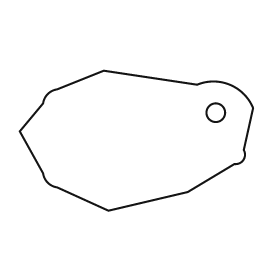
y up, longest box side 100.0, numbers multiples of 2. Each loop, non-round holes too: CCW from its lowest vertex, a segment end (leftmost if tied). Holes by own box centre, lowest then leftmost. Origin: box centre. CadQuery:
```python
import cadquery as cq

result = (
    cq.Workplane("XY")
    .moveTo(-12.0, -30.0)
    .lineTo(22.0, -22.0)
    .lineTo(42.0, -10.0)
    .threePointArc((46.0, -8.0), (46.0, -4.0))
    .lineTo(50.0, 14.0)
    .threePointArc((40.0, 24.0), (26.0, 24.0))
    .lineTo(-14.0, 30.0)
    .lineTo(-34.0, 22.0)
    .threePointArc((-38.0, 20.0), (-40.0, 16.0))
    .lineTo(-50.0, 4.0)
    .lineTo(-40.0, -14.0)
    .threePointArc((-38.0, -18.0), (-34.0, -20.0))
    .close()
    .moveTo(34.0, 12.0)
    .circle(4.0)
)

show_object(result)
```